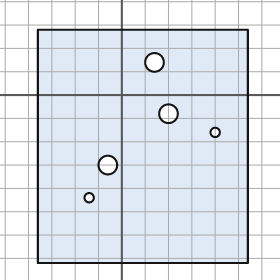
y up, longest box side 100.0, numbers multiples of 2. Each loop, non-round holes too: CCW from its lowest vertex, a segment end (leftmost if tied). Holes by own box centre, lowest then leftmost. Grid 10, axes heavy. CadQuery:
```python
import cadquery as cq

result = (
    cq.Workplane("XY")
    .moveTo(-36.0, -72.0)
    .lineTo(54.0, -72.0)
    .lineTo(54.0, 28.0)
    .lineTo(-36.0, 28.0)
    .close()
    .moveTo(-14.0, -44.0)
    .circle(2.0)
    .moveTo(-6.0, -30.0)
    .circle(4.0)
    .moveTo(40.0, -16.0)
    .circle(2.0)
    .moveTo(20.0, -8.0)
    .circle(4.0)
    .moveTo(14.0, 14.0)
    .circle(4.0)
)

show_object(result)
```